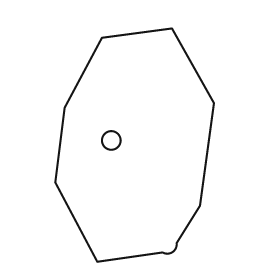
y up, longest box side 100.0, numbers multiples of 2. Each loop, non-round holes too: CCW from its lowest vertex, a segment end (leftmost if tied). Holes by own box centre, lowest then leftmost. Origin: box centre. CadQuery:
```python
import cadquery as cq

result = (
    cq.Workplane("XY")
    .moveTo(-16.0, -50.0)
    .lineTo(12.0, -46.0)
    .threePointArc((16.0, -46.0), (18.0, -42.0))
    .lineTo(28.0, -26.0)
    .lineTo(34.0, 18.0)
    .lineTo(16.0, 50.0)
    .lineTo(-14.0, 46.0)
    .lineTo(-30.0, 16.0)
    .lineTo(-34.0, -16.0)
    .close()
    .moveTo(-10.0, 2.0)
    .circle(4.0)
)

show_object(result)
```